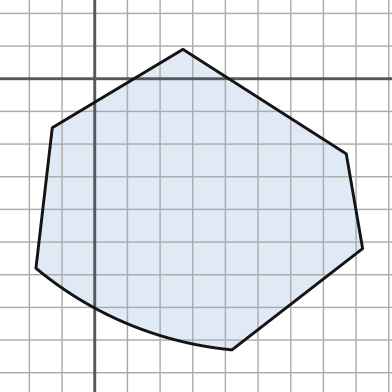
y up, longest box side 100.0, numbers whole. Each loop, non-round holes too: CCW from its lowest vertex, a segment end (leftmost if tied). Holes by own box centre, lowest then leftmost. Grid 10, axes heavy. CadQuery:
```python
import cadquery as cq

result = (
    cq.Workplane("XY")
    .moveTo(42.0, -83.0)
    .lineTo(82.0, -52.0)
    .lineTo(77.0, -23.0)
    .lineTo(27.0, 9.0)
    .lineTo(-13.0, -15.0)
    .lineTo(-18.0, -58.0)
    .threePointArc((10.0, -75.0), (42.0, -83.0))
    .close()
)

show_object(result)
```